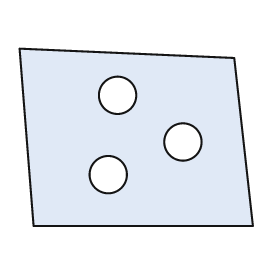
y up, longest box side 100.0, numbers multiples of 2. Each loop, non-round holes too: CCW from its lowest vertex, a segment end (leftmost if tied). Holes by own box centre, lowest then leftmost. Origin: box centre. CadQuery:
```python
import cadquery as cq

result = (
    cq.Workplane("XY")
    .moveTo(-44.0, -38.0)
    .lineTo(50.0, -38.0)
    .lineTo(42.0, 34.0)
    .lineTo(-50.0, 38.0)
    .close()
    .moveTo(-12.0, -16.0)
    .circle(8.0)
    .moveTo(20.0, -2.0)
    .circle(8.0)
    .moveTo(-8.0, 18.0)
    .circle(8.0)
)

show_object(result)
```